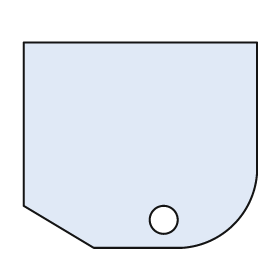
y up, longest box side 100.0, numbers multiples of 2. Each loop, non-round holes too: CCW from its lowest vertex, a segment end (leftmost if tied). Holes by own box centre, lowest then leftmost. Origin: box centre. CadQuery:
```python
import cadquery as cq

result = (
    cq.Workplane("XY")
    .moveTo(-20.0, -44.0)
    .lineTo(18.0, -44.0)
    .threePointArc((40.0, -34.0), (50.0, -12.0))
    .lineTo(50.0, 44.0)
    .lineTo(-50.0, 44.0)
    .lineTo(-50.0, -26.0)
    .close()
    .moveTo(10.0, -32.0)
    .circle(6.0)
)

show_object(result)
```